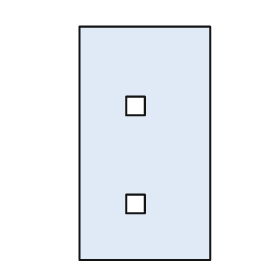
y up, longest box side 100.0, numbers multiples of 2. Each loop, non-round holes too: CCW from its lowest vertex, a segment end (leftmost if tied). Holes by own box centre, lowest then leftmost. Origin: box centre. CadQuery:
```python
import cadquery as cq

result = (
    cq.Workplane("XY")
    .moveTo(-28.0, -50.0)
    .lineTo(28.0, -50.0)
    .lineTo(28.0, 50.0)
    .lineTo(-28.0, 50.0)
    .close()
    .moveTo(-8.0, -30.0)
    .lineTo(0.0, -30.0)
    .lineTo(0.0, -22.0)
    .lineTo(-8.0, -22.0)
    .close()
    .moveTo(-8.0, 12.0)
    .lineTo(0.0, 12.0)
    .lineTo(0.0, 20.0)
    .lineTo(-8.0, 20.0)
    .close()
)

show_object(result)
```